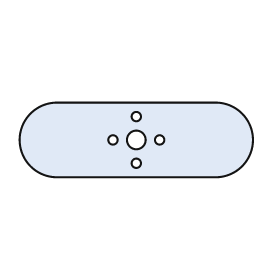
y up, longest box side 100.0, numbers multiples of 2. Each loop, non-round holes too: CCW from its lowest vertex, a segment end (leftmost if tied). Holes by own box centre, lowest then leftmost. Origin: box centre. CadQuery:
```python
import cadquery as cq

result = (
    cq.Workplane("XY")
    .moveTo(-34.0, -16.0)
    .lineTo(34.0, -16.0)
    .threePointArc((50.0, 0.0), (34.0, 16.0))
    .lineTo(-34.0, 16.0)
    .threePointArc((-50.0, 0.0), (-34.0, -16.0))
    .close()
    .moveTo(0.0, -10.0)
    .circle(2.0)
    .moveTo(-10.0, 0.0)
    .circle(2.0)
    .moveTo(0.0, 0.0)
    .circle(4.0)
    .moveTo(10.0, 0.0)
    .circle(2.0)
    .moveTo(0.0, 10.0)
    .circle(2.0)
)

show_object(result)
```